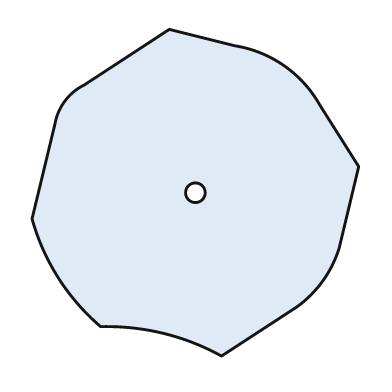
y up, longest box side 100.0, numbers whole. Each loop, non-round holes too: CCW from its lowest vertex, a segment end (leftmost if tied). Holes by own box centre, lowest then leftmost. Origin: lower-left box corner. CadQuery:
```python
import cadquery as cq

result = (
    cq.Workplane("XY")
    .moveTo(58.0, 0.0)
    .lineTo(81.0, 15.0)
    .threePointArc((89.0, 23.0), (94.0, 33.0))
    .lineTo(100.0, 58.0)
    .lineTo(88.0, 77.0)
    .threePointArc((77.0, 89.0), (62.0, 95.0))
    .lineTo(42.0, 100.0)
    .lineTo(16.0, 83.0)
    .threePointArc((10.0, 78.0), (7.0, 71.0))
    .lineTo(0.0, 42.0)
    .threePointArc((8.0, 24.0), (21.0, 9.0))
    .threePointArc((40.0, 7.0), (58.0, 0.0))
    .close()
    .moveTo(50.0, 50.0)
    .circle(3.0)
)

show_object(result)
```